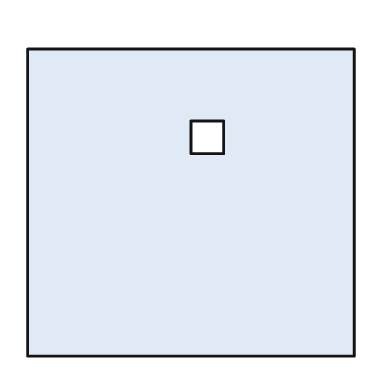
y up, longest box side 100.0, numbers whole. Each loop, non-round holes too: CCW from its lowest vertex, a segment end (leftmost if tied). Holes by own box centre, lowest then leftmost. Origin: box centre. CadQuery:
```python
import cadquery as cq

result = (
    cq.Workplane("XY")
    .moveTo(-50.0, -47.0)
    .lineTo(50.0, -47.0)
    .lineTo(50.0, 47.0)
    .lineTo(-50.0, 47.0)
    .close()
    .moveTo(0.0, 15.0)
    .lineTo(10.0, 15.0)
    .lineTo(10.0, 25.0)
    .lineTo(0.0, 25.0)
    .close()
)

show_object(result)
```